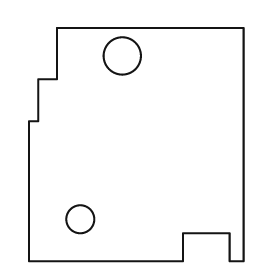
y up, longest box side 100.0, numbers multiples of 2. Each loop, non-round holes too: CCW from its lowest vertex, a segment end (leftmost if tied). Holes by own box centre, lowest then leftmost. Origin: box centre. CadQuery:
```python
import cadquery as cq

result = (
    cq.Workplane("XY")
    .moveTo(-46.0, -50.0)
    .lineTo(20.0, -50.0)
    .lineTo(20.0, -38.0)
    .lineTo(40.0, -38.0)
    .lineTo(40.0, -50.0)
    .lineTo(46.0, -50.0)
    .lineTo(46.0, 50.0)
    .lineTo(-34.0, 50.0)
    .lineTo(-34.0, 28.0)
    .lineTo(-42.0, 28.0)
    .lineTo(-42.0, 10.0)
    .lineTo(-46.0, 10.0)
    .close()
    .moveTo(-24.0, -32.0)
    .circle(6.0)
    .moveTo(-6.0, 38.0)
    .circle(8.0)
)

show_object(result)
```